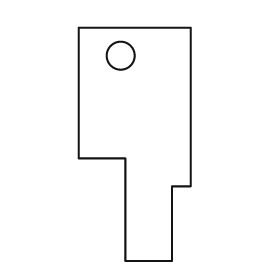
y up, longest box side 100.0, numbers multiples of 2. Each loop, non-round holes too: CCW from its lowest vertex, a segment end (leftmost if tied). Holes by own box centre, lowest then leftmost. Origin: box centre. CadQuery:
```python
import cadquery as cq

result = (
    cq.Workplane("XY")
    .moveTo(-4.0, -50.0)
    .lineTo(16.0, -50.0)
    .lineTo(16.0, -18.0)
    .lineTo(24.0, -18.0)
    .lineTo(24.0, 50.0)
    .lineTo(-24.0, 50.0)
    .lineTo(-24.0, -6.0)
    .lineTo(-4.0, -6.0)
    .close()
    .moveTo(-6.0, 38.0)
    .circle(6.0)
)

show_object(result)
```